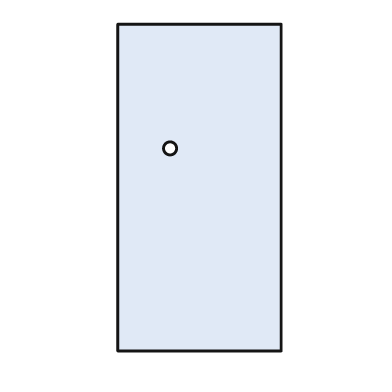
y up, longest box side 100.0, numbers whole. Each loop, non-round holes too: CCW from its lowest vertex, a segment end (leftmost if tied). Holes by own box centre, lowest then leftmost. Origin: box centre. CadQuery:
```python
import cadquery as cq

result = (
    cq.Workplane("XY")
    .moveTo(-25.0, -50.0)
    .lineTo(25.0, -50.0)
    .lineTo(25.0, 50.0)
    .lineTo(-25.0, 50.0)
    .close()
    .moveTo(-9.0, 12.0)
    .circle(2.0)
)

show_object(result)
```